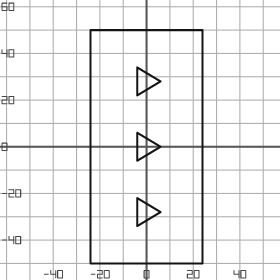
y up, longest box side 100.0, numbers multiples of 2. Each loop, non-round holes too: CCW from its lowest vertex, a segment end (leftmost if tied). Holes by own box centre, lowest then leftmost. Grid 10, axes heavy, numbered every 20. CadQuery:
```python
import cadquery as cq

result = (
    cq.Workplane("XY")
    .moveTo(-24.0, -50.0)
    .lineTo(24.0, -50.0)
    .lineTo(24.0, 50.0)
    .lineTo(-24.0, 50.0)
    .close()
    .moveTo(-4.0, -34.0)
    .lineTo(6.0, -28.0)
    .lineTo(-4.0, -22.0)
    .close()
    .moveTo(-4.0, -6.0)
    .lineTo(6.0, 0.0)
    .lineTo(-4.0, 6.0)
    .close()
    .moveTo(-4.0, 22.0)
    .lineTo(6.0, 28.0)
    .lineTo(-4.0, 34.0)
    .close()
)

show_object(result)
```